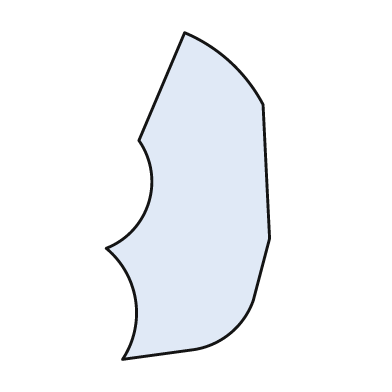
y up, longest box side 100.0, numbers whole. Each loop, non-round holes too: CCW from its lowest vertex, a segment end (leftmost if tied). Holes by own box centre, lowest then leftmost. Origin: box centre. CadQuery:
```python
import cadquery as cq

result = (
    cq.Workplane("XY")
    .moveTo(-20.0, -50.0)
    .lineTo(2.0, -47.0)
    .threePointArc((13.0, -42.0), (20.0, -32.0))
    .lineTo(25.0, -13.0)
    .lineTo(23.0, 28.0)
    .threePointArc((13.0, 41.0), (-1.0, 50.0))
    .lineTo(-15.0, 17.0)
    .threePointArc((-12.0, -2.0), (-25.0, -16.0))
    .threePointArc((-16.0, -32.0), (-20.0, -50.0))
    .close()
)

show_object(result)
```